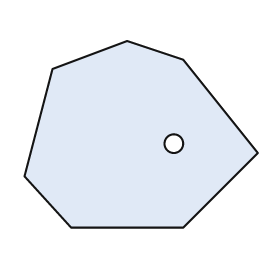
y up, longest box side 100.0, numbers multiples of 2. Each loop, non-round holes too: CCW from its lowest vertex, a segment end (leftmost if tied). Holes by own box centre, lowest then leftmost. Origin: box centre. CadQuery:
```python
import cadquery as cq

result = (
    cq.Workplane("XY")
    .moveTo(-30.0, -40.0)
    .lineTo(18.0, -40.0)
    .lineTo(50.0, -8.0)
    .lineTo(18.0, 32.0)
    .lineTo(-6.0, 40.0)
    .lineTo(-38.0, 28.0)
    .lineTo(-50.0, -18.0)
    .close()
    .moveTo(14.0, -4.0)
    .circle(4.0)
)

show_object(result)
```